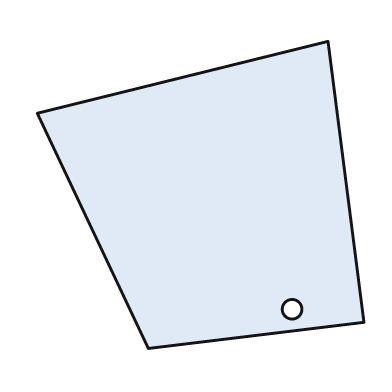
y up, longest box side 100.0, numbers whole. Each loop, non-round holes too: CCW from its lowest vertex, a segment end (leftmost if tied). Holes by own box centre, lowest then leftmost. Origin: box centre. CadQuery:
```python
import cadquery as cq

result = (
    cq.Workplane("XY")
    .moveTo(-16.0, -47.0)
    .lineTo(50.0, -39.0)
    .lineTo(39.0, 47.0)
    .lineTo(-50.0, 25.0)
    .close()
    .moveTo(28.0, -35.0)
    .circle(3.0)
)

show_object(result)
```